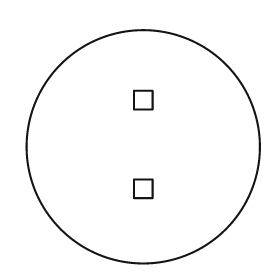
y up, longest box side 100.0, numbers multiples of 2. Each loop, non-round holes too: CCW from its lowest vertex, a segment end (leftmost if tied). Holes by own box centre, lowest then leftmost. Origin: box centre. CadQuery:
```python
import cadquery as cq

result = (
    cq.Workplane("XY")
    .moveTo(0.0, 0.0)
    .circle(50.0)
    .moveTo(-4.0, -22.0)
    .lineTo(4.0, -22.0)
    .lineTo(4.0, -14.0)
    .lineTo(-4.0, -14.0)
    .close()
    .moveTo(-4.0, 16.0)
    .lineTo(4.0, 16.0)
    .lineTo(4.0, 24.0)
    .lineTo(-4.0, 24.0)
    .close()
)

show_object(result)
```